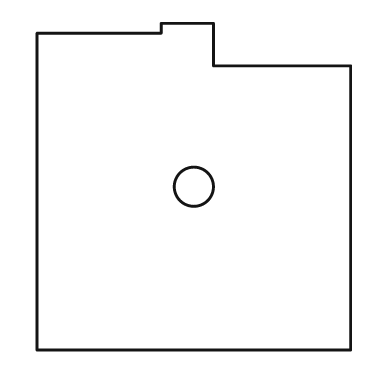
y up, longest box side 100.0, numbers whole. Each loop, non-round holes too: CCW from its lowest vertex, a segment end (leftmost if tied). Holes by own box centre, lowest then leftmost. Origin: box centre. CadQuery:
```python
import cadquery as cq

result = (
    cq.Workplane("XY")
    .moveTo(-48.0, -50.0)
    .lineTo(48.0, -50.0)
    .lineTo(48.0, 37.0)
    .lineTo(6.0, 37.0)
    .lineTo(6.0, 50.0)
    .lineTo(-10.0, 50.0)
    .lineTo(-10.0, 47.0)
    .lineTo(-48.0, 47.0)
    .close()
    .moveTo(0.0, 0.0)
    .circle(6.0)
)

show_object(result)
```